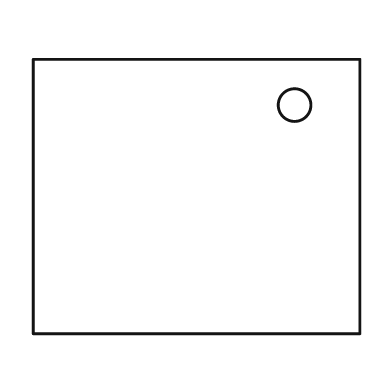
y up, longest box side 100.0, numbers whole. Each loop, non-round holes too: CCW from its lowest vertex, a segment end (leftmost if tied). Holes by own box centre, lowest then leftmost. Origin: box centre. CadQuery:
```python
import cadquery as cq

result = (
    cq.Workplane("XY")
    .moveTo(-50.0, -42.0)
    .lineTo(50.0, -42.0)
    .lineTo(50.0, 42.0)
    .lineTo(-50.0, 42.0)
    .close()
    .moveTo(30.0, 28.0)
    .circle(5.0)
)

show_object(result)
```